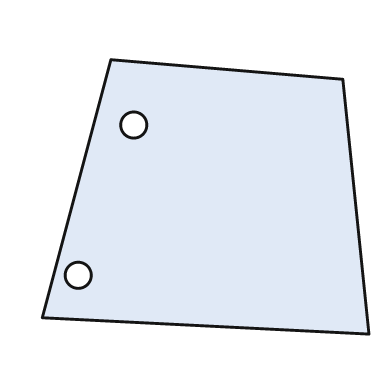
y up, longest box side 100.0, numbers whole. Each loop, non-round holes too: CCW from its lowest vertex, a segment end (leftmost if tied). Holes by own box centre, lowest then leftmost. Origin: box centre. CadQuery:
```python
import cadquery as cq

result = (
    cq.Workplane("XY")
    .moveTo(50.0, -42.0)
    .lineTo(42.0, 36.0)
    .lineTo(-29.0, 42.0)
    .lineTo(-50.0, -37.0)
    .close()
    .moveTo(-39.0, -24.0)
    .circle(4.0)
    .moveTo(-22.0, 22.0)
    .circle(4.0)
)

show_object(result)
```